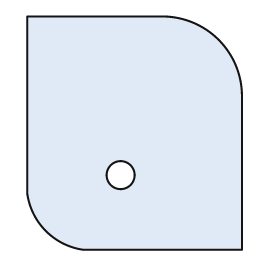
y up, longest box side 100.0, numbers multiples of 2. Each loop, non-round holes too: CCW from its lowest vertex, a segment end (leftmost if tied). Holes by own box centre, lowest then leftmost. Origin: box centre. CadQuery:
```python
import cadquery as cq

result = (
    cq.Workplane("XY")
    .moveTo(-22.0, -50.0)
    .lineTo(46.0, -50.0)
    .lineTo(46.0, 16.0)
    .threePointArc((36.0, 40.0), (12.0, 50.0))
    .lineTo(-46.0, 50.0)
    .lineTo(-46.0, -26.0)
    .threePointArc((-38.0, -42.0), (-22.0, -50.0))
    .close()
    .moveTo(-6.0, -18.0)
    .circle(6.0)
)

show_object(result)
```